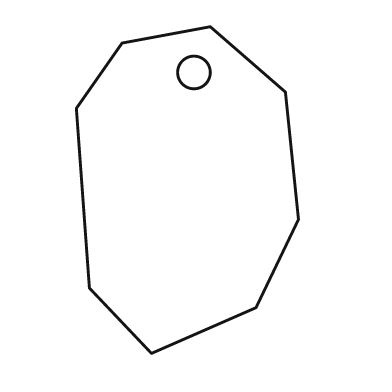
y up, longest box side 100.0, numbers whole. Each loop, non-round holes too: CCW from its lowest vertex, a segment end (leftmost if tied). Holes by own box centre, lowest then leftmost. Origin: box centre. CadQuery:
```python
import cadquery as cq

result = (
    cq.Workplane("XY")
    .moveTo(-11.0, -50.0)
    .lineTo(21.0, -36.0)
    .lineTo(34.0, -9.0)
    .lineTo(30.0, 30.0)
    .lineTo(7.0, 50.0)
    .lineTo(-20.0, 45.0)
    .lineTo(-34.0, 25.0)
    .lineTo(-30.0, -30.0)
    .close()
    .moveTo(2.0, 36.0)
    .circle(5.0)
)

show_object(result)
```